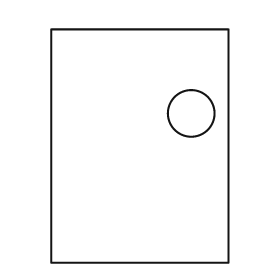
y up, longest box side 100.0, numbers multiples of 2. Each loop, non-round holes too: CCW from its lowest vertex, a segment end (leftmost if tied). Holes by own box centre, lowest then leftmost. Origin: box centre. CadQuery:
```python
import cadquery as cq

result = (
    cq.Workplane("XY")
    .moveTo(-38.0, -50.0)
    .lineTo(38.0, -50.0)
    .lineTo(38.0, 50.0)
    .lineTo(-38.0, 50.0)
    .close()
    .moveTo(22.0, 14.0)
    .circle(10.0)
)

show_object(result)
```